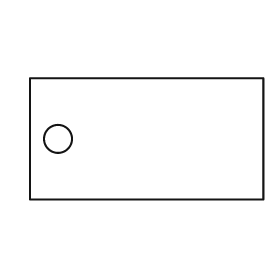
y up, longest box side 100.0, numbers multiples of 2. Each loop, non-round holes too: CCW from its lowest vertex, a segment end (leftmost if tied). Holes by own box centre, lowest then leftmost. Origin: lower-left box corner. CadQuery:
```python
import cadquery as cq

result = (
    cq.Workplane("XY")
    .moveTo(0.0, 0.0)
    .lineTo(100.0, 0.0)
    .lineTo(100.0, 52.0)
    .lineTo(0.0, 52.0)
    .close()
    .moveTo(12.0, 26.0)
    .circle(6.0)
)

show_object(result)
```